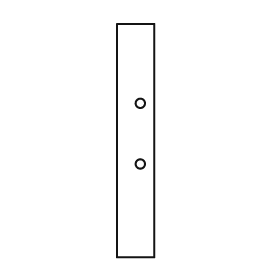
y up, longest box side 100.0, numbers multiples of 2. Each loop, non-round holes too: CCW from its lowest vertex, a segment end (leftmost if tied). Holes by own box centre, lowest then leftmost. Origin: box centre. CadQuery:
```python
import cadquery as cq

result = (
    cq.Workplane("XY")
    .moveTo(-8.0, -50.0)
    .lineTo(8.0, -50.0)
    .lineTo(8.0, 50.0)
    .lineTo(-8.0, 50.0)
    .close()
    .moveTo(2.0, -10.0)
    .circle(2.0)
    .moveTo(2.0, 16.0)
    .circle(2.0)
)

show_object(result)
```